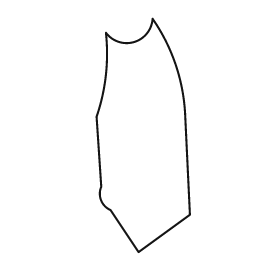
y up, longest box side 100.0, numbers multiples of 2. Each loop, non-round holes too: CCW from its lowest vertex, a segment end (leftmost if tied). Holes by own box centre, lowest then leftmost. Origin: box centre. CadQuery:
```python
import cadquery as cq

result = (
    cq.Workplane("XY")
    .moveTo(-2.0, -50.0)
    .lineTo(20.0, -34.0)
    .lineTo(18.0, 8.0)
    .threePointArc((14.0, 30.0), (4.0, 50.0))
    .threePointArc((-4.0, 40.0), (-16.0, 44.0))
    .threePointArc((-16.0, 26.0), (-20.0, 8.0))
    .lineTo(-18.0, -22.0)
    .threePointArc((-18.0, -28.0), (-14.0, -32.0))
    .close()
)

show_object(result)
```